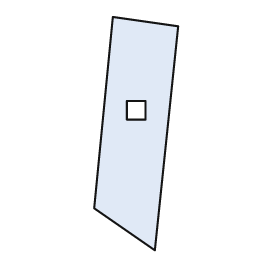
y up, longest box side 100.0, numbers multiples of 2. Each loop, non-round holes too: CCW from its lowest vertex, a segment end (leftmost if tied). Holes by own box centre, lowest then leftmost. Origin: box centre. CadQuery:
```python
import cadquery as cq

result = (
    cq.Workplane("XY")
    .moveTo(8.0, -50.0)
    .lineTo(18.0, 46.0)
    .lineTo(-10.0, 50.0)
    .lineTo(-18.0, -32.0)
    .close()
    .moveTo(-4.0, 6.0)
    .lineTo(4.0, 6.0)
    .lineTo(4.0, 14.0)
    .lineTo(-4.0, 14.0)
    .close()
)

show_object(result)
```